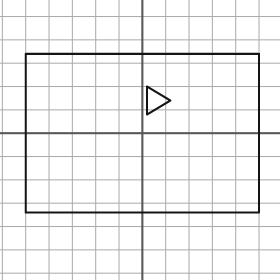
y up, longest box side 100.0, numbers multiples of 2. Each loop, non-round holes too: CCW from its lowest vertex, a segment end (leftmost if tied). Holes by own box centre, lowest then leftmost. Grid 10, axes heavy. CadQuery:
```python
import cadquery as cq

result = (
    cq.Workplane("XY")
    .moveTo(-50.0, -34.0)
    .lineTo(50.0, -34.0)
    .lineTo(50.0, 34.0)
    .lineTo(-50.0, 34.0)
    .close()
    .moveTo(2.0, 8.0)
    .lineTo(12.0, 14.0)
    .lineTo(2.0, 20.0)
    .close()
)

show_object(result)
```